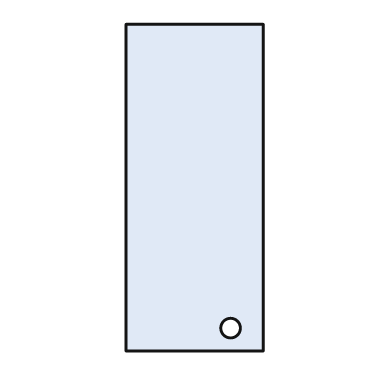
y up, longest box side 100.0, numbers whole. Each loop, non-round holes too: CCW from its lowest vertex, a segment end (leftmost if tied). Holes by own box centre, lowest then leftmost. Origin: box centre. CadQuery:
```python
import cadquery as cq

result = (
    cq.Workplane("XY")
    .moveTo(-21.0, -50.0)
    .lineTo(21.0, -50.0)
    .lineTo(21.0, 50.0)
    .lineTo(-21.0, 50.0)
    .close()
    .moveTo(11.0, -43.0)
    .circle(3.0)
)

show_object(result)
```